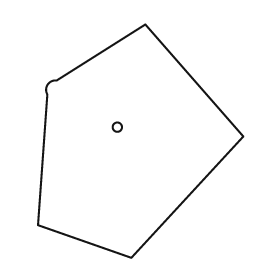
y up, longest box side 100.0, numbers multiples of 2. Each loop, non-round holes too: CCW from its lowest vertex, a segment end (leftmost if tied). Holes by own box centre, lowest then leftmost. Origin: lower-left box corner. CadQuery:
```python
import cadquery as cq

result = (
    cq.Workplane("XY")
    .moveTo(40.0, 0.0)
    .lineTo(88.0, 52.0)
    .lineTo(46.0, 100.0)
    .lineTo(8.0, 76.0)
    .threePointArc((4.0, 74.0), (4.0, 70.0))
    .lineTo(0.0, 14.0)
    .close()
    .moveTo(34.0, 56.0)
    .circle(2.0)
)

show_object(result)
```